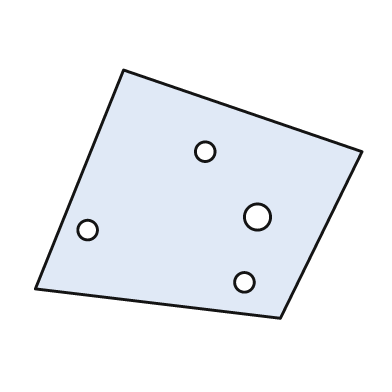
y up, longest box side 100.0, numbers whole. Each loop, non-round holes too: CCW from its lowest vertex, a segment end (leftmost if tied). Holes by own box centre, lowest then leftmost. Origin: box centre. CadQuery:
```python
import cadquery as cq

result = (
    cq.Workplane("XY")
    .moveTo(25.0, -38.0)
    .lineTo(50.0, 13.0)
    .lineTo(-23.0, 38.0)
    .lineTo(-50.0, -29.0)
    .close()
    .moveTo(14.0, -27.0)
    .circle(3.0)
    .moveTo(-34.0, -11.0)
    .circle(3.0)
    .moveTo(18.0, -7.0)
    .circle(4.0)
    .moveTo(2.0, 13.0)
    .circle(3.0)
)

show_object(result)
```